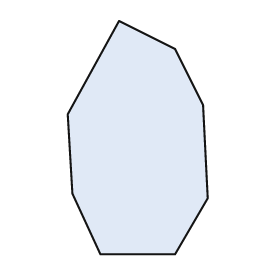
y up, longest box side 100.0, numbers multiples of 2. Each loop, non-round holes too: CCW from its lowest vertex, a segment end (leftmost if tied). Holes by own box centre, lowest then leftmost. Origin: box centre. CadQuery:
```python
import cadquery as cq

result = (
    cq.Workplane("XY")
    .moveTo(-16.0, -50.0)
    .lineTo(16.0, -50.0)
    .lineTo(30.0, -26.0)
    .lineTo(28.0, 14.0)
    .lineTo(16.0, 38.0)
    .lineTo(-8.0, 50.0)
    .lineTo(-30.0, 10.0)
    .lineTo(-28.0, -24.0)
    .close()
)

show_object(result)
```